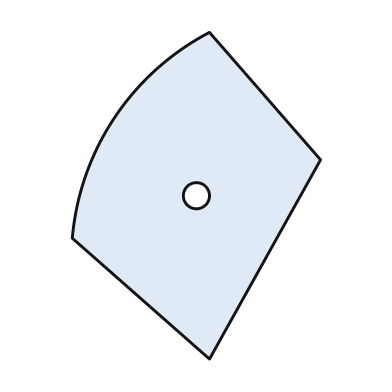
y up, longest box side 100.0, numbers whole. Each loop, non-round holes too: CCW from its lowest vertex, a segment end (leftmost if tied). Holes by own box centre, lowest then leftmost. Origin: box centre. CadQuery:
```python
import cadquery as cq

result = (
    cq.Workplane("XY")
    .moveTo(4.0, -50.0)
    .lineTo(38.0, 11.0)
    .lineTo(4.0, 50.0)
    .threePointArc((-25.0, 24.0), (-38.0, -13.0))
    .close()
    .moveTo(0.0, 0.0)
    .circle(4.0)
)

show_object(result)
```